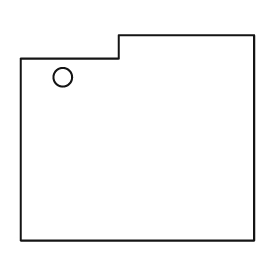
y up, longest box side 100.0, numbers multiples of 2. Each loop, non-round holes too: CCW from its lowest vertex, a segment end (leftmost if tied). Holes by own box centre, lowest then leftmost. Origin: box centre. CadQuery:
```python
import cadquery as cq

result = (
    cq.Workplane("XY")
    .moveTo(-50.0, -44.0)
    .lineTo(50.0, -44.0)
    .lineTo(50.0, 44.0)
    .lineTo(-8.0, 44.0)
    .lineTo(-8.0, 34.0)
    .lineTo(-50.0, 34.0)
    .close()
    .moveTo(-32.0, 26.0)
    .circle(4.0)
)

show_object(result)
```